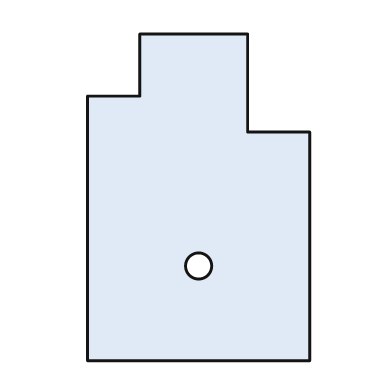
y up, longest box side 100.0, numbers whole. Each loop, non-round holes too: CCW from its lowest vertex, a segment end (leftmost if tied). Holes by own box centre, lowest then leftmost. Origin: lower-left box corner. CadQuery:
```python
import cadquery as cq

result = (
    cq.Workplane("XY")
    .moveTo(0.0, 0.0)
    .lineTo(68.0, 0.0)
    .lineTo(68.0, 70.0)
    .lineTo(49.0, 70.0)
    .lineTo(49.0, 100.0)
    .lineTo(16.0, 100.0)
    .lineTo(16.0, 81.0)
    .lineTo(0.0, 81.0)
    .close()
    .moveTo(34.0, 29.0)
    .circle(4.0)
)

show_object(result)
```